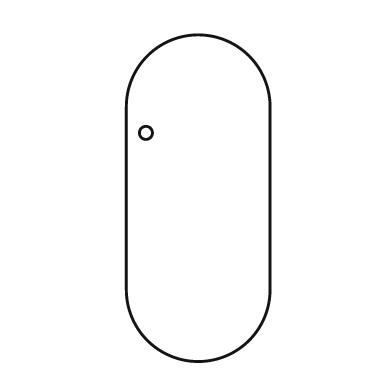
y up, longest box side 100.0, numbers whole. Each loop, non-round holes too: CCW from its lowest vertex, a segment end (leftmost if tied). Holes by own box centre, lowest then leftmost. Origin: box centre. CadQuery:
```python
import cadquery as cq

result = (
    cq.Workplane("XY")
    .moveTo(-22.0, -28.0)
    .threePointArc((0.0, -50.0), (22.0, -28.0))
    .lineTo(22.0, 28.0)
    .threePointArc((0.0, 50.0), (-22.0, 28.0))
    .close()
    .moveTo(-16.0, 20.0)
    .circle(2.0)
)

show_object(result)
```